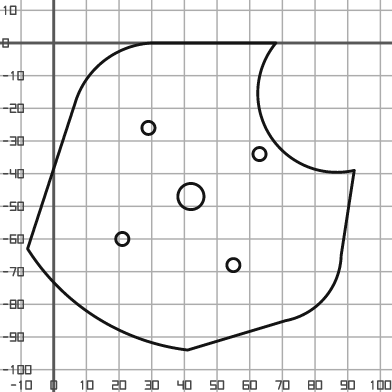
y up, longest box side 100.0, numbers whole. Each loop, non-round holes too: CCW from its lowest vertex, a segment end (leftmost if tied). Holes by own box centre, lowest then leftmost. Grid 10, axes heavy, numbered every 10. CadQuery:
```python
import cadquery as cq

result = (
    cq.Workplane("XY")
    .moveTo(41.0, -94.0)
    .lineTo(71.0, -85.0)
    .threePointArc((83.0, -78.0), (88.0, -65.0))
    .lineTo(92.0, -39.0)
    .threePointArc((66.0, -28.0), (68.0, 0.0))
    .lineTo(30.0, 0.0)
    .threePointArc((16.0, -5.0), (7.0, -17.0))
    .lineTo(-8.0, -63.0)
    .threePointArc((13.0, -84.0), (41.0, -94.0))
    .close()
    .moveTo(55.0, -68.0)
    .circle(2.0)
    .moveTo(21.0, -60.0)
    .circle(2.0)
    .moveTo(42.0, -47.0)
    .circle(4.0)
    .moveTo(63.0, -34.0)
    .circle(2.0)
    .moveTo(29.0, -26.0)
    .circle(2.0)
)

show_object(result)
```